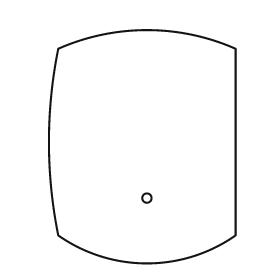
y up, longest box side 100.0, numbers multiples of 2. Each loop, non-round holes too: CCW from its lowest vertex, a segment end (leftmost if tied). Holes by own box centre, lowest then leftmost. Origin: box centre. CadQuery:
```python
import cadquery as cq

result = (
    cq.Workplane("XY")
    .moveTo(-36.0, -38.0)
    .threePointArc((2.0, -50.0), (40.0, -38.0))
    .lineTo(40.0, 42.0)
    .threePointArc((2.0, 50.0), (-36.0, 42.0))
    .threePointArc((-40.0, 2.0), (-36.0, -38.0))
    .close()
    .moveTo(2.0, -22.0)
    .circle(2.0)
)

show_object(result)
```